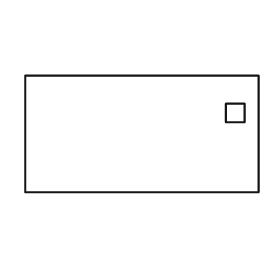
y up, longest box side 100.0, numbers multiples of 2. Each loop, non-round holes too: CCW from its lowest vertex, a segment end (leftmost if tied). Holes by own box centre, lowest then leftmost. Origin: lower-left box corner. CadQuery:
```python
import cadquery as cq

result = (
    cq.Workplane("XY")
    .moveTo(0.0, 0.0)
    .lineTo(100.0, 0.0)
    .lineTo(100.0, 50.0)
    .lineTo(0.0, 50.0)
    .close()
    .moveTo(86.0, 30.0)
    .lineTo(94.0, 30.0)
    .lineTo(94.0, 38.0)
    .lineTo(86.0, 38.0)
    .close()
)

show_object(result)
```